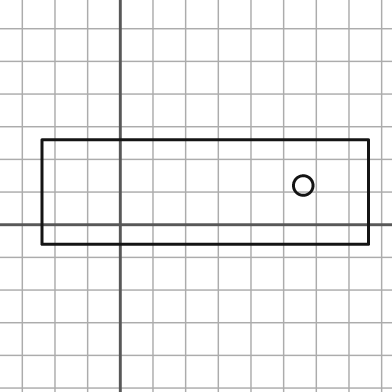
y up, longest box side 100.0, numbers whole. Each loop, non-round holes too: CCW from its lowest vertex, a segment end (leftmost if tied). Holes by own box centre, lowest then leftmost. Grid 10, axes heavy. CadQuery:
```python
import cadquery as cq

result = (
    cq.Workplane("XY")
    .moveTo(-24.0, -6.0)
    .lineTo(76.0, -6.0)
    .lineTo(76.0, 26.0)
    .lineTo(-24.0, 26.0)
    .close()
    .moveTo(56.0, 12.0)
    .circle(3.0)
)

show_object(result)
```